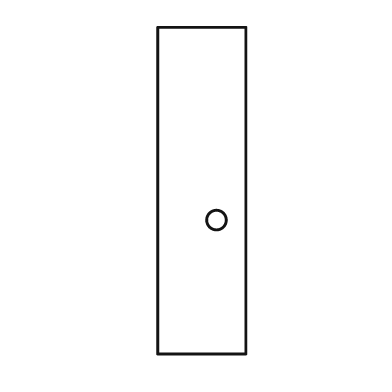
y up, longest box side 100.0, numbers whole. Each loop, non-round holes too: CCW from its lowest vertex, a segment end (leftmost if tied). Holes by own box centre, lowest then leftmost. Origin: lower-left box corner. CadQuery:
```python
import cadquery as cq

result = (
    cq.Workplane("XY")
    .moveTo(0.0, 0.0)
    .lineTo(27.0, 0.0)
    .lineTo(27.0, 100.0)
    .lineTo(0.0, 100.0)
    .close()
    .moveTo(18.0, 41.0)
    .circle(3.0)
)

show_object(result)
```